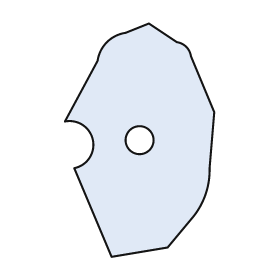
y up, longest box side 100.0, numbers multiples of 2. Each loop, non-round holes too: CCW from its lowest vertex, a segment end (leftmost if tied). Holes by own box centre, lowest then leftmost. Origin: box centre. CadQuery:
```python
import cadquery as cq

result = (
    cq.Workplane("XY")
    .moveTo(-12.0, -50.0)
    .lineTo(12.0, -46.0)
    .lineTo(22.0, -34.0)
    .threePointArc((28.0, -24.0), (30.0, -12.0))
    .lineTo(32.0, 12.0)
    .lineTo(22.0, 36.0)
    .threePointArc((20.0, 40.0), (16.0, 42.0))
    .lineTo(4.0, 50.0)
    .lineTo(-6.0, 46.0)
    .threePointArc((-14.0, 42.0), (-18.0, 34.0))
    .lineTo(-32.0, 8.0)
    .threePointArc((-20.0, 0.0), (-28.0, -12.0))
    .close()
    .moveTo(0.0, 0.0)
    .circle(6.0)
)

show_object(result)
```